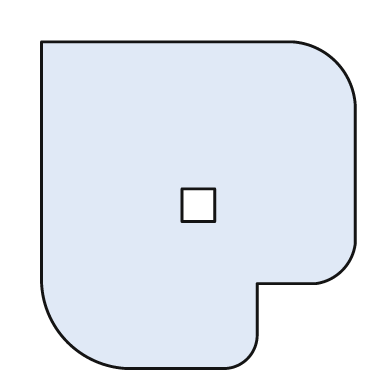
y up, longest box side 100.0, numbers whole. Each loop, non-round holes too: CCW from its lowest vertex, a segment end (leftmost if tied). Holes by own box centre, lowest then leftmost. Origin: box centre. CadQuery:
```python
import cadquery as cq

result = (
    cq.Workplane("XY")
    .moveTo(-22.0, -50.0)
    .lineTo(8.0, -50.0)
    .threePointArc((15.0, -47.0), (18.0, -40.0))
    .lineTo(18.0, -24.0)
    .lineTo(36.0, -24.0)
    .threePointArc((44.0, -20.0), (48.0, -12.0))
    .lineTo(48.0, 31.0)
    .threePointArc((42.0, 44.0), (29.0, 50.0))
    .lineTo(-48.0, 50.0)
    .lineTo(-48.0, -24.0)
    .threePointArc((-40.0, -42.0), (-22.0, -50.0))
    .close()
    .moveTo(-5.0, -5.0)
    .lineTo(5.0, -5.0)
    .lineTo(5.0, 5.0)
    .lineTo(-5.0, 5.0)
    .close()
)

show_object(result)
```